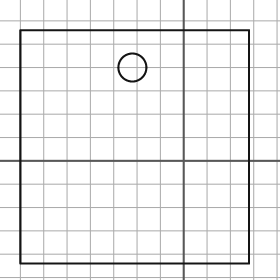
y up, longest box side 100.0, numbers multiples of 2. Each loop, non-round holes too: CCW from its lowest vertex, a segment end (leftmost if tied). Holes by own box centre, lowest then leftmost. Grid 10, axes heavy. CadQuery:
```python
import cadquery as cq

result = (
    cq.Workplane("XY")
    .moveTo(-70.0, -44.0)
    .lineTo(28.0, -44.0)
    .lineTo(28.0, 56.0)
    .lineTo(-70.0, 56.0)
    .close()
    .moveTo(-22.0, 40.0)
    .circle(6.0)
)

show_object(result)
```